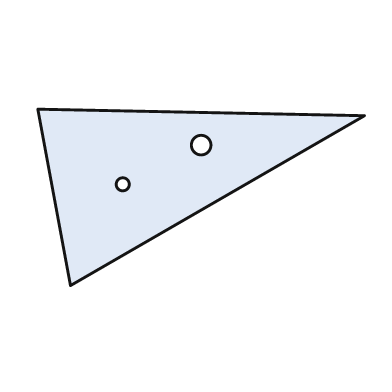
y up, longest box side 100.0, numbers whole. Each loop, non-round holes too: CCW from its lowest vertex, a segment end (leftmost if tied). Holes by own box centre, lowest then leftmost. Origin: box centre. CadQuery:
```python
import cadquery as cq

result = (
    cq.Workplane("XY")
    .moveTo(-40.0, -27.0)
    .lineTo(50.0, 25.0)
    .lineTo(-50.0, 27.0)
    .close()
    .moveTo(-24.0, 4.0)
    .circle(2.0)
    .moveTo(0.0, 16.0)
    .circle(3.0)
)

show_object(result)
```